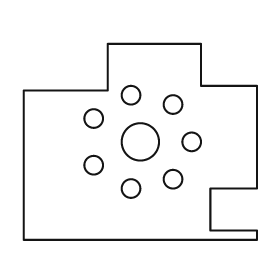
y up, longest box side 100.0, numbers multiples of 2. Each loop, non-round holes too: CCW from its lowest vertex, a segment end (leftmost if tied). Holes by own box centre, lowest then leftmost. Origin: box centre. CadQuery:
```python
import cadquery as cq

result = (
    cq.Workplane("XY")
    .moveTo(-50.0, -42.0)
    .lineTo(50.0, -42.0)
    .lineTo(50.0, -38.0)
    .lineTo(30.0, -38.0)
    .lineTo(30.0, -20.0)
    .lineTo(50.0, -20.0)
    .lineTo(50.0, 24.0)
    .lineTo(26.0, 24.0)
    .lineTo(26.0, 42.0)
    .lineTo(-14.0, 42.0)
    .lineTo(-14.0, 22.0)
    .lineTo(-50.0, 22.0)
    .close()
    .moveTo(-4.0, -20.0)
    .circle(4.0)
    .moveTo(14.0, -16.0)
    .circle(4.0)
    .moveTo(-20.0, -10.0)
    .circle(4.0)
    .moveTo(0.0, 0.0)
    .circle(8.0)
    .moveTo(22.0, 0.0)
    .circle(4.0)
    .moveTo(-20.0, 10.0)
    .circle(4.0)
    .moveTo(14.0, 16.0)
    .circle(4.0)
    .moveTo(-4.0, 20.0)
    .circle(4.0)
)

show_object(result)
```